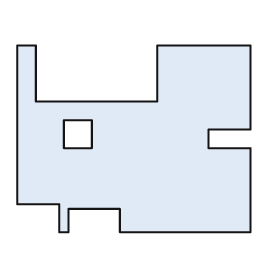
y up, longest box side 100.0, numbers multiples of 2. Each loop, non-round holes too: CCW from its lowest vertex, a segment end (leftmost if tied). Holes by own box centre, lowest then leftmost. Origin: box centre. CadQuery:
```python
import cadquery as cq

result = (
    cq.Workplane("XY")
    .moveTo(-32.0, -40.0)
    .lineTo(-28.0, -40.0)
    .lineTo(-28.0, -30.0)
    .lineTo(-6.0, -30.0)
    .lineTo(-6.0, -40.0)
    .lineTo(50.0, -40.0)
    .lineTo(50.0, -4.0)
    .lineTo(32.0, -4.0)
    .lineTo(32.0, 4.0)
    .lineTo(50.0, 4.0)
    .lineTo(50.0, 40.0)
    .lineTo(10.0, 40.0)
    .lineTo(10.0, 16.0)
    .lineTo(-42.0, 16.0)
    .lineTo(-42.0, 40.0)
    .lineTo(-50.0, 40.0)
    .lineTo(-50.0, -28.0)
    .lineTo(-32.0, -28.0)
    .close()
    .moveTo(-30.0, -4.0)
    .lineTo(-18.0, -4.0)
    .lineTo(-18.0, 8.0)
    .lineTo(-30.0, 8.0)
    .close()
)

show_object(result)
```